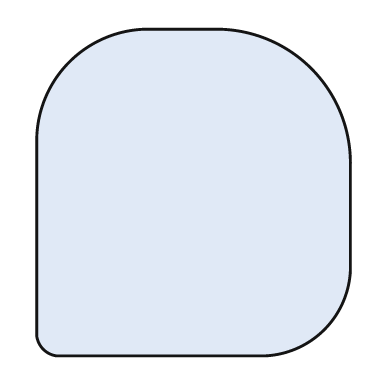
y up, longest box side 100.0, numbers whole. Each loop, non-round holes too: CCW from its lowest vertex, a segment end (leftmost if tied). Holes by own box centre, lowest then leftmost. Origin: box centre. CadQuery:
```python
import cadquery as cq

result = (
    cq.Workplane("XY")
    .moveTo(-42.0, -50.0)
    .lineTo(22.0, -50.0)
    .threePointArc((40.0, -42.0), (48.0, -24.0))
    .lineTo(48.0, 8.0)
    .threePointArc((36.0, 38.0), (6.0, 50.0))
    .lineTo(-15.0, 50.0)
    .threePointArc((-38.0, 40.0), (-48.0, 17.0))
    .lineTo(-48.0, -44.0)
    .threePointArc((-46.0, -48.0), (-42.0, -50.0))
    .close()
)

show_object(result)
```